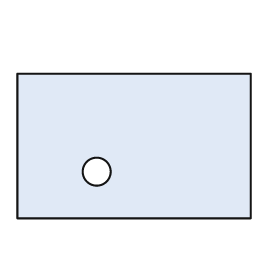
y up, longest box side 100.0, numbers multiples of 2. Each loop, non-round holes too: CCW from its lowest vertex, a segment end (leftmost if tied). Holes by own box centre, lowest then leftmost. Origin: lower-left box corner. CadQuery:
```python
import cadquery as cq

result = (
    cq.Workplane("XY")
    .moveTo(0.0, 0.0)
    .lineTo(100.0, 0.0)
    .lineTo(100.0, 62.0)
    .lineTo(0.0, 62.0)
    .close()
    .moveTo(34.0, 20.0)
    .circle(6.0)
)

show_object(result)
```